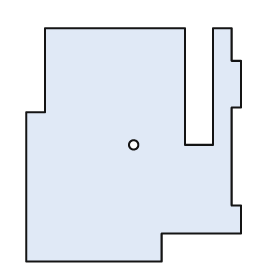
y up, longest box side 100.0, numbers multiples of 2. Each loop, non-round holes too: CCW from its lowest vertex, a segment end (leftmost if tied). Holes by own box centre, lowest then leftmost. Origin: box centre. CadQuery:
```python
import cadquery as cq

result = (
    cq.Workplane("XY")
    .moveTo(-46.0, -50.0)
    .lineTo(12.0, -50.0)
    .lineTo(12.0, -38.0)
    .lineTo(46.0, -38.0)
    .lineTo(46.0, -26.0)
    .lineTo(42.0, -26.0)
    .lineTo(42.0, 16.0)
    .lineTo(46.0, 16.0)
    .lineTo(46.0, 36.0)
    .lineTo(42.0, 36.0)
    .lineTo(42.0, 50.0)
    .lineTo(34.0, 50.0)
    .lineTo(34.0, 0.0)
    .lineTo(22.0, 0.0)
    .lineTo(22.0, 50.0)
    .lineTo(-38.0, 50.0)
    .lineTo(-38.0, 14.0)
    .lineTo(-46.0, 14.0)
    .close()
    .moveTo(0.0, 0.0)
    .circle(2.0)
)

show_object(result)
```